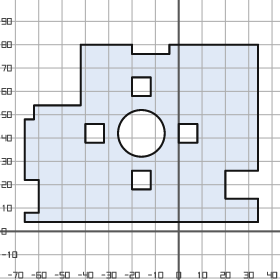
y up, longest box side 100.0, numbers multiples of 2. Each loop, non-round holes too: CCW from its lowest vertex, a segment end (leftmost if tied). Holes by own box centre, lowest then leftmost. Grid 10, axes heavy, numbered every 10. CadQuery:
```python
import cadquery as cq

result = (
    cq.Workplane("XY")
    .moveTo(-66.0, 4.0)
    .lineTo(34.0, 4.0)
    .lineTo(34.0, 14.0)
    .lineTo(20.0, 14.0)
    .lineTo(20.0, 26.0)
    .lineTo(34.0, 26.0)
    .lineTo(34.0, 80.0)
    .lineTo(-4.0, 80.0)
    .lineTo(-4.0, 76.0)
    .lineTo(-20.0, 76.0)
    .lineTo(-20.0, 80.0)
    .lineTo(-42.0, 80.0)
    .lineTo(-42.0, 54.0)
    .lineTo(-62.0, 54.0)
    .lineTo(-62.0, 48.0)
    .lineTo(-66.0, 48.0)
    .lineTo(-66.0, 22.0)
    .lineTo(-60.0, 22.0)
    .lineTo(-60.0, 8.0)
    .lineTo(-66.0, 8.0)
    .close()
    .moveTo(-20.0, 18.0)
    .lineTo(-12.0, 18.0)
    .lineTo(-12.0, 26.0)
    .lineTo(-20.0, 26.0)
    .close()
    .moveTo(-40.0, 38.0)
    .lineTo(-32.0, 38.0)
    .lineTo(-32.0, 46.0)
    .lineTo(-40.0, 46.0)
    .close()
    .moveTo(-16.0, 42.0)
    .circle(10.0)
    .moveTo(0.0, 38.0)
    .lineTo(8.0, 38.0)
    .lineTo(8.0, 46.0)
    .lineTo(0.0, 46.0)
    .close()
    .moveTo(-20.0, 58.0)
    .lineTo(-12.0, 58.0)
    .lineTo(-12.0, 66.0)
    .lineTo(-20.0, 66.0)
    .close()
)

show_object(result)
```